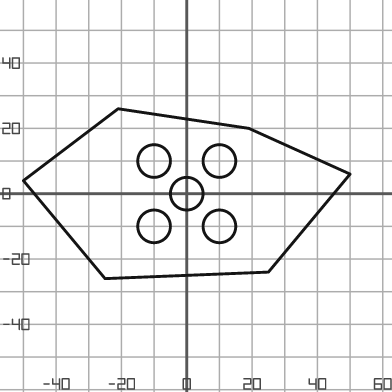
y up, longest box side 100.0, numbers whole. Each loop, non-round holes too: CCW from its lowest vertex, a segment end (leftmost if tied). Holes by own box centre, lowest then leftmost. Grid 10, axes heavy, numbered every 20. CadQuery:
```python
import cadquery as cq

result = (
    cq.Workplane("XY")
    .moveTo(-25.0, -26.0)
    .lineTo(25.0, -24.0)
    .lineTo(50.0, 6.0)
    .lineTo(19.0, 20.0)
    .lineTo(-21.0, 26.0)
    .lineTo(-50.0, 4.0)
    .close()
    .moveTo(-10.0, -10.0)
    .circle(5.0)
    .moveTo(10.0, -10.0)
    .circle(5.0)
    .moveTo(0.0, 0.0)
    .circle(5.0)
    .moveTo(-10.0, 10.0)
    .circle(5.0)
    .moveTo(10.0, 10.0)
    .circle(5.0)
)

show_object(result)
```